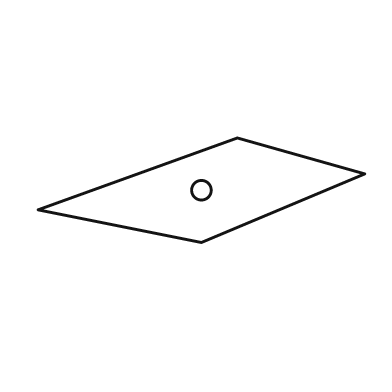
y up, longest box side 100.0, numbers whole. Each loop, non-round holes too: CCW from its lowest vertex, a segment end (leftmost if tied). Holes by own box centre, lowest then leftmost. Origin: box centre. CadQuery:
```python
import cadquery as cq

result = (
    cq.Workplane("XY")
    .moveTo(0.0, -16.0)
    .lineTo(50.0, 5.0)
    .lineTo(11.0, 16.0)
    .lineTo(-50.0, -6.0)
    .close()
    .moveTo(0.0, 0.0)
    .circle(3.0)
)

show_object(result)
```